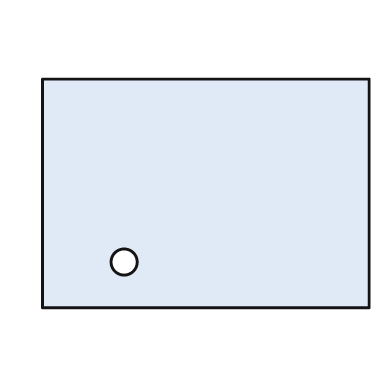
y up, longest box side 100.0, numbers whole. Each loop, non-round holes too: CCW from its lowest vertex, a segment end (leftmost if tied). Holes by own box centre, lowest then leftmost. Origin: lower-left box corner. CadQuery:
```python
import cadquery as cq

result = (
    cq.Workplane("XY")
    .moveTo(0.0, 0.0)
    .lineTo(100.0, 0.0)
    .lineTo(100.0, 70.0)
    .lineTo(0.0, 70.0)
    .close()
    .moveTo(25.0, 14.0)
    .circle(4.0)
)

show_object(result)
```